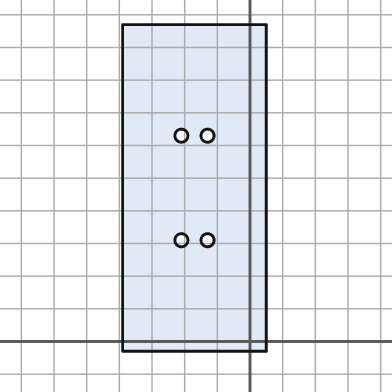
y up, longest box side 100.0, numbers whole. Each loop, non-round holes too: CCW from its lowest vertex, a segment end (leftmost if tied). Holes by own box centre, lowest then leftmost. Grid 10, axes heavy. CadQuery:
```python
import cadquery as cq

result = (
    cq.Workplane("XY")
    .moveTo(-39.0, -3.0)
    .lineTo(5.0, -3.0)
    .lineTo(5.0, 97.0)
    .lineTo(-39.0, 97.0)
    .close()
    .moveTo(-21.0, 31.0)
    .circle(2.0)
    .moveTo(-13.0, 31.0)
    .circle(2.0)
    .moveTo(-21.0, 63.0)
    .circle(2.0)
    .moveTo(-13.0, 63.0)
    .circle(2.0)
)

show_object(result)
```